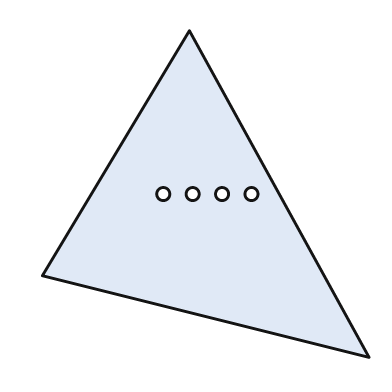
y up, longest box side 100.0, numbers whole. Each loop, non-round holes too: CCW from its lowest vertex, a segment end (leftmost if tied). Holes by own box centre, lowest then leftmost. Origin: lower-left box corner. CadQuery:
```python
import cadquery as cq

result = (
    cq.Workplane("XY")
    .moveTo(100.0, 0.0)
    .lineTo(45.0, 100.0)
    .lineTo(0.0, 25.0)
    .close()
    .moveTo(37.0, 50.0)
    .circle(2.0)
    .moveTo(46.0, 50.0)
    .circle(2.0)
    .moveTo(55.0, 50.0)
    .circle(2.0)
    .moveTo(64.0, 50.0)
    .circle(2.0)
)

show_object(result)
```